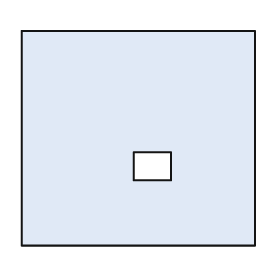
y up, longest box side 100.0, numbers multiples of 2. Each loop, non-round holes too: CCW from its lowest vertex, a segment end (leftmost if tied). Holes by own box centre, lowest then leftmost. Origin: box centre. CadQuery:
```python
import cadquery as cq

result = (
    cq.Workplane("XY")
    .moveTo(-50.0, -46.0)
    .lineTo(50.0, -46.0)
    .lineTo(50.0, 46.0)
    .lineTo(-50.0, 46.0)
    .close()
    .moveTo(-2.0, -18.0)
    .lineTo(14.0, -18.0)
    .lineTo(14.0, -6.0)
    .lineTo(-2.0, -6.0)
    .close()
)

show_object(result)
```